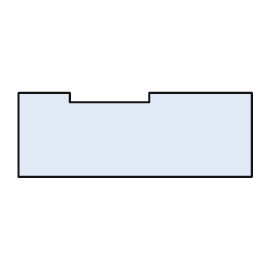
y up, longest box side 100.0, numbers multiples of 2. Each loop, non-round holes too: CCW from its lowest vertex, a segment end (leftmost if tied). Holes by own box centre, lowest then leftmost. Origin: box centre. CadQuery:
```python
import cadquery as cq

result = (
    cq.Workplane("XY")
    .moveTo(-50.0, -18.0)
    .lineTo(50.0, -18.0)
    .lineTo(50.0, 18.0)
    .lineTo(6.0, 18.0)
    .lineTo(6.0, 14.0)
    .lineTo(-28.0, 14.0)
    .lineTo(-28.0, 18.0)
    .lineTo(-50.0, 18.0)
    .close()
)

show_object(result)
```